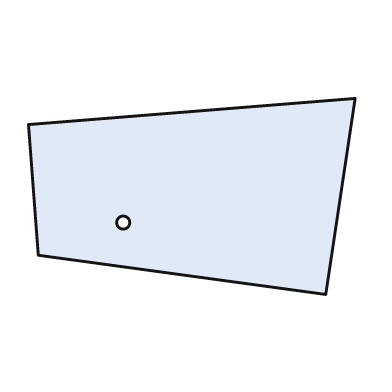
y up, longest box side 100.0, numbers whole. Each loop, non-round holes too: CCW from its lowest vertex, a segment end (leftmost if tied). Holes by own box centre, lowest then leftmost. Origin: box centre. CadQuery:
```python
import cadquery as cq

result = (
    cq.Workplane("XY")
    .moveTo(41.0, -30.0)
    .lineTo(50.0, 30.0)
    .lineTo(-50.0, 22.0)
    .lineTo(-47.0, -18.0)
    .close()
    .moveTo(-21.0, -8.0)
    .circle(2.0)
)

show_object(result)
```